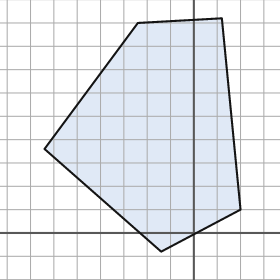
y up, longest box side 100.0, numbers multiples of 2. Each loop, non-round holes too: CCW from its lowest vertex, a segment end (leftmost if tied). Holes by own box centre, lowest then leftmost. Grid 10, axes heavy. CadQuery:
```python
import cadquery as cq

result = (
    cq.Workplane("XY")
    .moveTo(-14.0, -8.0)
    .lineTo(20.0, 10.0)
    .lineTo(12.0, 92.0)
    .lineTo(-24.0, 90.0)
    .lineTo(-64.0, 36.0)
    .close()
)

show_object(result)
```